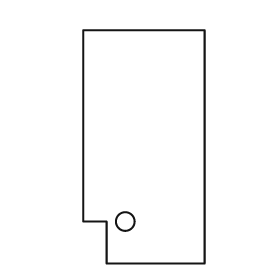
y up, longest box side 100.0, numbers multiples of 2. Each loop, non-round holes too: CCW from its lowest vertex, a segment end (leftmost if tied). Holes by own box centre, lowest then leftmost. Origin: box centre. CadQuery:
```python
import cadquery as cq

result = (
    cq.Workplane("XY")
    .moveTo(-16.0, -50.0)
    .lineTo(26.0, -50.0)
    .lineTo(26.0, 50.0)
    .lineTo(-26.0, 50.0)
    .lineTo(-26.0, -32.0)
    .lineTo(-16.0, -32.0)
    .close()
    .moveTo(-8.0, -32.0)
    .circle(4.0)
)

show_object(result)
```